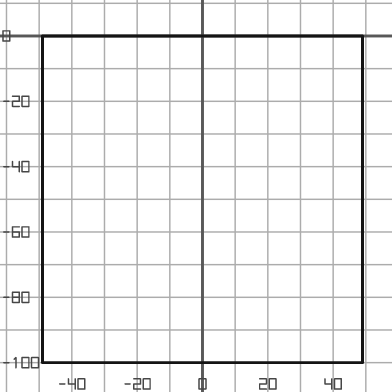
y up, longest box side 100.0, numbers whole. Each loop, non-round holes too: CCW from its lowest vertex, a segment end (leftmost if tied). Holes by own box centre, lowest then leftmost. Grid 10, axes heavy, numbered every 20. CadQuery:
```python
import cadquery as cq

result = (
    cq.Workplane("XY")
    .moveTo(-49.0, -100.0)
    .lineTo(49.0, -100.0)
    .lineTo(49.0, 0.0)
    .lineTo(-49.0, 0.0)
    .close()
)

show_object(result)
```